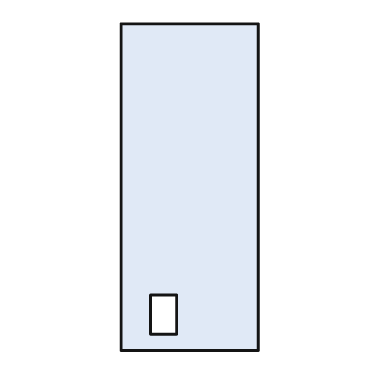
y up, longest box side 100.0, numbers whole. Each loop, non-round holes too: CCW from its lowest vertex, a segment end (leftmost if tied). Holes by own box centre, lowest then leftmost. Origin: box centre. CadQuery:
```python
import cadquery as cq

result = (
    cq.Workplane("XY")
    .moveTo(-21.0, -50.0)
    .lineTo(21.0, -50.0)
    .lineTo(21.0, 50.0)
    .lineTo(-21.0, 50.0)
    .close()
    .moveTo(-12.0, -45.0)
    .lineTo(-4.0, -45.0)
    .lineTo(-4.0, -33.0)
    .lineTo(-12.0, -33.0)
    .close()
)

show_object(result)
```